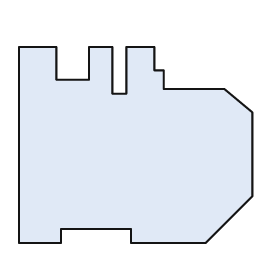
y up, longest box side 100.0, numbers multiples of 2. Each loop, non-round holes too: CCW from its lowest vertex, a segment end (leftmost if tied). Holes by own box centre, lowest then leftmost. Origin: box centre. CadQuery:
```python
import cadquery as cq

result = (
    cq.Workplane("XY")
    .moveTo(-50.0, -42.0)
    .lineTo(-32.0, -42.0)
    .lineTo(-32.0, -36.0)
    .lineTo(-2.0, -36.0)
    .lineTo(-2.0, -42.0)
    .lineTo(30.0, -42.0)
    .lineTo(50.0, -22.0)
    .lineTo(50.0, 14.0)
    .lineTo(38.0, 24.0)
    .lineTo(12.0, 24.0)
    .lineTo(12.0, 32.0)
    .lineTo(8.0, 32.0)
    .lineTo(8.0, 42.0)
    .lineTo(-4.0, 42.0)
    .lineTo(-4.0, 22.0)
    .lineTo(-10.0, 22.0)
    .lineTo(-10.0, 42.0)
    .lineTo(-20.0, 42.0)
    .lineTo(-20.0, 28.0)
    .lineTo(-34.0, 28.0)
    .lineTo(-34.0, 42.0)
    .lineTo(-50.0, 42.0)
    .close()
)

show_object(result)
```